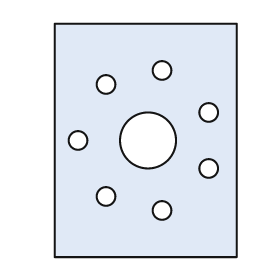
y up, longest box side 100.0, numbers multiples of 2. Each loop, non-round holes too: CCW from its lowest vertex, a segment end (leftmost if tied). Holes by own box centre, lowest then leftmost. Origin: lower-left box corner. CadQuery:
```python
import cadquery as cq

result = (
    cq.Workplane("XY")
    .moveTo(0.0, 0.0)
    .lineTo(78.0, 0.0)
    .lineTo(78.0, 100.0)
    .lineTo(0.0, 100.0)
    .close()
    .moveTo(46.0, 20.0)
    .circle(4.0)
    .moveTo(22.0, 26.0)
    .circle(4.0)
    .moveTo(66.0, 38.0)
    .circle(4.0)
    .moveTo(10.0, 50.0)
    .circle(4.0)
    .moveTo(40.0, 50.0)
    .circle(12.0)
    .moveTo(66.0, 62.0)
    .circle(4.0)
    .moveTo(22.0, 74.0)
    .circle(4.0)
    .moveTo(46.0, 80.0)
    .circle(4.0)
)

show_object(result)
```